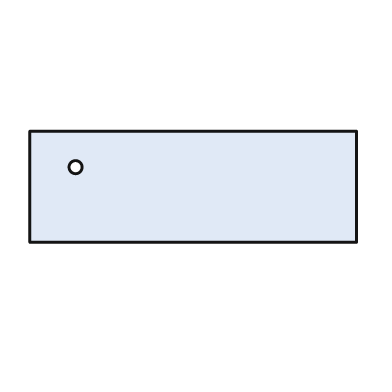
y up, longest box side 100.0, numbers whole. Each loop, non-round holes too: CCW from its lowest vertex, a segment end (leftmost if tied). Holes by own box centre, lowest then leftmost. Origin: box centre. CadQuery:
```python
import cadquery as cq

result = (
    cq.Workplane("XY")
    .moveTo(-50.0, -17.0)
    .lineTo(50.0, -17.0)
    .lineTo(50.0, 17.0)
    .lineTo(-50.0, 17.0)
    .close()
    .moveTo(-36.0, 6.0)
    .circle(2.0)
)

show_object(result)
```